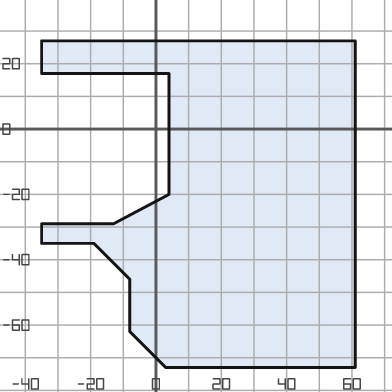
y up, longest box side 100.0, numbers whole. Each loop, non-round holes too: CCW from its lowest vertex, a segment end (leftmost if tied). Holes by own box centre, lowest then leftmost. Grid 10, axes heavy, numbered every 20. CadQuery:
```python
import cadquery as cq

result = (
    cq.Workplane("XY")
    .moveTo(3.0, -73.0)
    .lineTo(61.0, -73.0)
    .lineTo(61.0, 27.0)
    .lineTo(-35.0, 27.0)
    .lineTo(-35.0, 17.0)
    .lineTo(4.0, 17.0)
    .lineTo(4.0, -20.0)
    .lineTo(-13.0, -29.0)
    .lineTo(-35.0, -29.0)
    .lineTo(-35.0, -35.0)
    .lineTo(-19.0, -35.0)
    .lineTo(-8.0, -46.0)
    .lineTo(-8.0, -62.0)
    .close()
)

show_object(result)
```